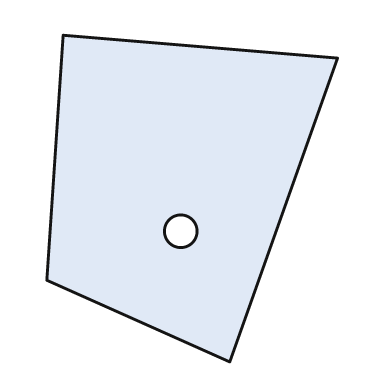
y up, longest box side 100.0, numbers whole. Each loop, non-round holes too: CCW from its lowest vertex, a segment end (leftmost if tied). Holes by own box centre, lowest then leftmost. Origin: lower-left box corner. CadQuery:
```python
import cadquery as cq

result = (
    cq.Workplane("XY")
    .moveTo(56.0, 0.0)
    .lineTo(89.0, 93.0)
    .lineTo(5.0, 100.0)
    .lineTo(0.0, 25.0)
    .close()
    .moveTo(41.0, 40.0)
    .circle(5.0)
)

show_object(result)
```